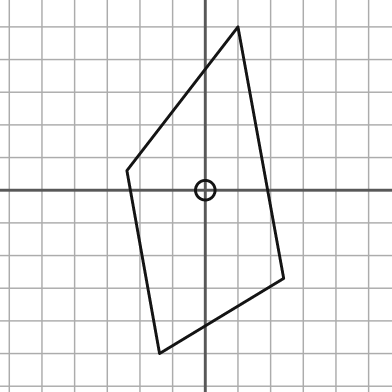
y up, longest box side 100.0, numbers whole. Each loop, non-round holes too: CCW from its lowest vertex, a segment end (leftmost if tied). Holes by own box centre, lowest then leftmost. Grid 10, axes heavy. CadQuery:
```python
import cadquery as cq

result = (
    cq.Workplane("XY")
    .moveTo(-14.0, -50.0)
    .lineTo(24.0, -27.0)
    .lineTo(10.0, 50.0)
    .lineTo(-24.0, 6.0)
    .close()
    .moveTo(0.0, 0.0)
    .circle(3.0)
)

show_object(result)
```